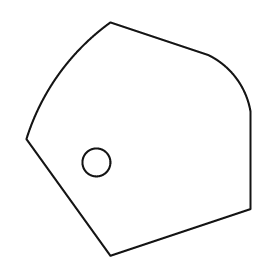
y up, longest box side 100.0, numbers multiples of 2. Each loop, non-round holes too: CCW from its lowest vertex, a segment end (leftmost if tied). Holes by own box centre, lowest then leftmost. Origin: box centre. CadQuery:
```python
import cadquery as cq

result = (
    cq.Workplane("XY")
    .moveTo(-12.0, -50.0)
    .lineTo(48.0, -30.0)
    .lineTo(48.0, 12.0)
    .threePointArc((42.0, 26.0), (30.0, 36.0))
    .lineTo(-12.0, 50.0)
    .threePointArc((-34.0, 28.0), (-48.0, 0.0))
    .close()
    .moveTo(-18.0, -10.0)
    .circle(6.0)
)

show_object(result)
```